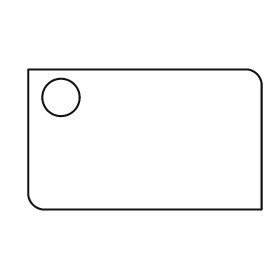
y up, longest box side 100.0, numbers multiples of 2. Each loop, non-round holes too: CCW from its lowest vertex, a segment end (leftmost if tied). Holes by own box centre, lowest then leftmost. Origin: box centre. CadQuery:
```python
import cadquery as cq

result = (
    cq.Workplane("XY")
    .moveTo(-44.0, -30.0)
    .lineTo(50.0, -30.0)
    .lineTo(50.0, 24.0)
    .threePointArc((48.0, 28.0), (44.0, 30.0))
    .lineTo(-50.0, 30.0)
    .lineTo(-50.0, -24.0)
    .threePointArc((-48.0, -28.0), (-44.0, -30.0))
    .close()
    .moveTo(-36.0, 18.0)
    .circle(8.0)
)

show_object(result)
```